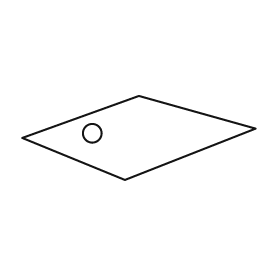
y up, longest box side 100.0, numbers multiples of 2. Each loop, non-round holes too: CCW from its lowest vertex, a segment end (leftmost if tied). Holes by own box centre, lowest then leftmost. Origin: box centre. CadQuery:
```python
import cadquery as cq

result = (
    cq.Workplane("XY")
    .moveTo(-6.0, -18.0)
    .lineTo(50.0, 4.0)
    .lineTo(0.0, 18.0)
    .lineTo(-50.0, 0.0)
    .close()
    .moveTo(-20.0, 2.0)
    .circle(4.0)
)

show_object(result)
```